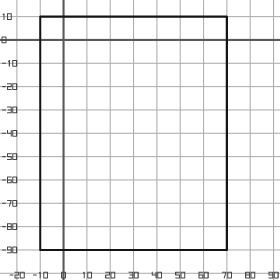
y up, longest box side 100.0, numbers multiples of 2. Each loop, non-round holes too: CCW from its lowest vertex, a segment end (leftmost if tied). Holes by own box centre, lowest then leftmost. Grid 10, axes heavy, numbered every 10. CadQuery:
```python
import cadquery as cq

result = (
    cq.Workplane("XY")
    .moveTo(-10.0, -90.0)
    .lineTo(70.0, -90.0)
    .lineTo(70.0, 10.0)
    .lineTo(-10.0, 10.0)
    .close()
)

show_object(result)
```